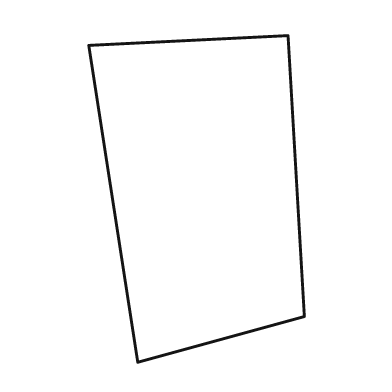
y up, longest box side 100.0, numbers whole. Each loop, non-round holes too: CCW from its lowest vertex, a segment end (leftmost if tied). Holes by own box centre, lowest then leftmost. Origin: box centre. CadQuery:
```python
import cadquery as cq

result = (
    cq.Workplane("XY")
    .moveTo(-18.0, -50.0)
    .lineTo(33.0, -36.0)
    .lineTo(28.0, 50.0)
    .lineTo(-33.0, 47.0)
    .close()
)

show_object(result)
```